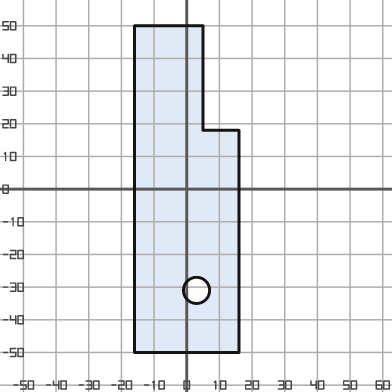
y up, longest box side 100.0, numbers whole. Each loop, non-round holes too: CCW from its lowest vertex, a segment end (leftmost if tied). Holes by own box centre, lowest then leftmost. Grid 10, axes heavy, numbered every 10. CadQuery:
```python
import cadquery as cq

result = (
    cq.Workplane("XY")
    .moveTo(-16.0, -50.0)
    .lineTo(16.0, -50.0)
    .lineTo(16.0, 18.0)
    .lineTo(5.0, 18.0)
    .lineTo(5.0, 50.0)
    .lineTo(-16.0, 50.0)
    .close()
    .moveTo(3.0, -31.0)
    .circle(4.0)
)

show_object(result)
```